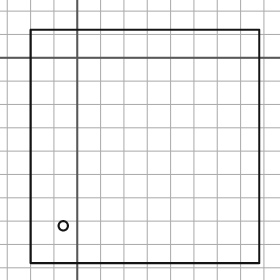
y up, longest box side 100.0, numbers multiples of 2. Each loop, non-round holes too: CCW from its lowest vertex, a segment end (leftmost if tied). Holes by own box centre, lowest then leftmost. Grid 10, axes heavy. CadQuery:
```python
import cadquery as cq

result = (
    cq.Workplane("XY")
    .moveTo(-20.0, -88.0)
    .lineTo(78.0, -88.0)
    .lineTo(78.0, 12.0)
    .lineTo(-20.0, 12.0)
    .close()
    .moveTo(-6.0, -72.0)
    .circle(2.0)
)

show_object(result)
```